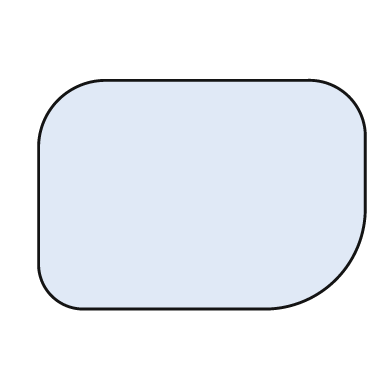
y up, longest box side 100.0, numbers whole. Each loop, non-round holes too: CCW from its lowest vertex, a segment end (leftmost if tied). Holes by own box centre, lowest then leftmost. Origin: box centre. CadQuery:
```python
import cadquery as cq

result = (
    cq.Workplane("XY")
    .moveTo(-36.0, -35.0)
    .lineTo(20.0, -35.0)
    .threePointArc((41.0, -26.0), (50.0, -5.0))
    .lineTo(50.0, 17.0)
    .threePointArc((45.0, 30.0), (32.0, 35.0))
    .lineTo(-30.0, 35.0)
    .threePointArc((-44.0, 29.0), (-50.0, 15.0))
    .lineTo(-50.0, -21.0)
    .threePointArc((-46.0, -31.0), (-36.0, -35.0))
    .close()
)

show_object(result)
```